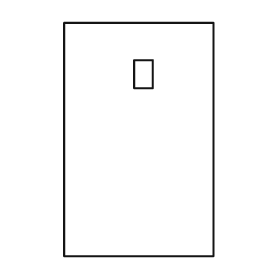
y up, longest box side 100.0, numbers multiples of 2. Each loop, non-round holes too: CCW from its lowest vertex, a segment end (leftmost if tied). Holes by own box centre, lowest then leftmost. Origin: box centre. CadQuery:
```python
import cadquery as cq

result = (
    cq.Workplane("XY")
    .moveTo(-32.0, -50.0)
    .lineTo(32.0, -50.0)
    .lineTo(32.0, 50.0)
    .lineTo(-32.0, 50.0)
    .close()
    .moveTo(-2.0, 22.0)
    .lineTo(6.0, 22.0)
    .lineTo(6.0, 34.0)
    .lineTo(-2.0, 34.0)
    .close()
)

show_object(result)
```